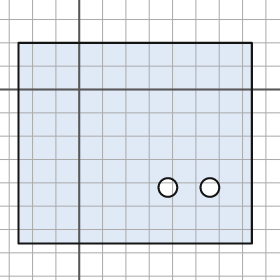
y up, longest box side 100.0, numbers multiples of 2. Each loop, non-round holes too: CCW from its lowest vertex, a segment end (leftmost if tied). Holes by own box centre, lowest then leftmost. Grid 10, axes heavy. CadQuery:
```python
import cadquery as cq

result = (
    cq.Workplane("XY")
    .moveTo(-26.0, -66.0)
    .lineTo(74.0, -66.0)
    .lineTo(74.0, 20.0)
    .lineTo(-26.0, 20.0)
    .close()
    .moveTo(38.0, -42.0)
    .circle(4.0)
    .moveTo(56.0, -42.0)
    .circle(4.0)
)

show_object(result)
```